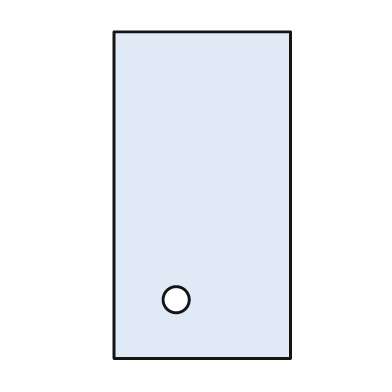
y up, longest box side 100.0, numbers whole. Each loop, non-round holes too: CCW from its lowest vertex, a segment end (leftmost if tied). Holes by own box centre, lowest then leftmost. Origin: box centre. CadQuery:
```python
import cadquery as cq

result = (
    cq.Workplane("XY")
    .moveTo(-27.0, -50.0)
    .lineTo(27.0, -50.0)
    .lineTo(27.0, 50.0)
    .lineTo(-27.0, 50.0)
    .close()
    .moveTo(-8.0, -32.0)
    .circle(4.0)
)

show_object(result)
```